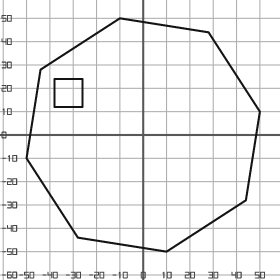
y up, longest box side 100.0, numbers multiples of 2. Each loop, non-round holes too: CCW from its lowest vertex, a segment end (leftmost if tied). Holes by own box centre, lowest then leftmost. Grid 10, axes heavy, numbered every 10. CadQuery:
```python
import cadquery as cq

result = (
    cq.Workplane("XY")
    .moveTo(10.0, -50.0)
    .lineTo(44.0, -28.0)
    .lineTo(50.0, 10.0)
    .lineTo(28.0, 44.0)
    .lineTo(-10.0, 50.0)
    .lineTo(-44.0, 28.0)
    .lineTo(-50.0, -10.0)
    .lineTo(-28.0, -44.0)
    .close()
    .moveTo(-38.0, 12.0)
    .lineTo(-26.0, 12.0)
    .lineTo(-26.0, 24.0)
    .lineTo(-38.0, 24.0)
    .close()
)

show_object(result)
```